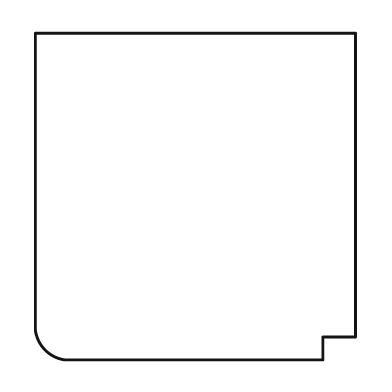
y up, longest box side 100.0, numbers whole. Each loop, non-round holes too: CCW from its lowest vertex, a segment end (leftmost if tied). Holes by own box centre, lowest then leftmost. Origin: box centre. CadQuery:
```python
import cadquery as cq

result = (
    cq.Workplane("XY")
    .moveTo(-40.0, -50.0)
    .lineTo(39.0, -50.0)
    .lineTo(39.0, -43.0)
    .lineTo(49.0, -43.0)
    .lineTo(49.0, 50.0)
    .lineTo(-49.0, 50.0)
    .lineTo(-49.0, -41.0)
    .threePointArc((-46.0, -47.0), (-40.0, -50.0))
    .close()
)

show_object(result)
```